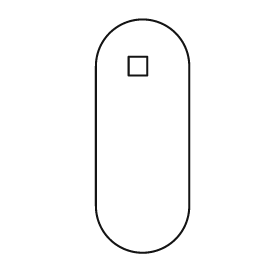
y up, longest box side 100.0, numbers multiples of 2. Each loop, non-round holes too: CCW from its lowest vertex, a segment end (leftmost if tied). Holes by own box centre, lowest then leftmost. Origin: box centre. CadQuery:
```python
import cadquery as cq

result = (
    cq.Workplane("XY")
    .moveTo(-20.0, -30.0)
    .threePointArc((0.0, -50.0), (20.0, -30.0))
    .lineTo(20.0, 30.0)
    .threePointArc((0.0, 50.0), (-20.0, 30.0))
    .close()
    .moveTo(-6.0, 26.0)
    .lineTo(2.0, 26.0)
    .lineTo(2.0, 34.0)
    .lineTo(-6.0, 34.0)
    .close()
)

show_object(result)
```